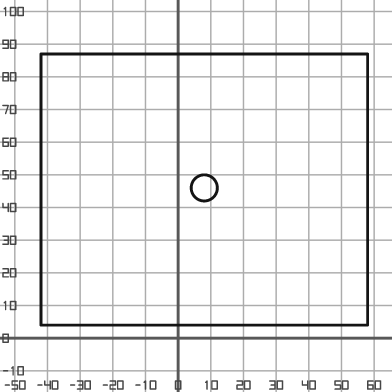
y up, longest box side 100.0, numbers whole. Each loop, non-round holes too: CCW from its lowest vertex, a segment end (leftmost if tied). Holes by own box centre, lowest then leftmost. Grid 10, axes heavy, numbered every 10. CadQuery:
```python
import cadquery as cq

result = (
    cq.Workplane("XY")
    .moveTo(-42.0, 4.0)
    .lineTo(58.0, 4.0)
    .lineTo(58.0, 87.0)
    .lineTo(-42.0, 87.0)
    .close()
    .moveTo(8.0, 46.0)
    .circle(4.0)
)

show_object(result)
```